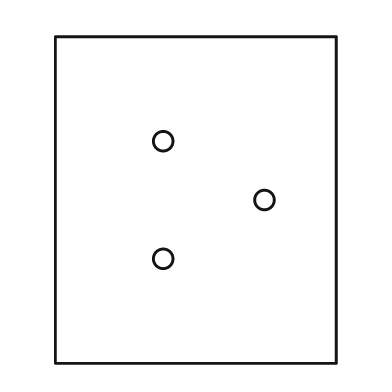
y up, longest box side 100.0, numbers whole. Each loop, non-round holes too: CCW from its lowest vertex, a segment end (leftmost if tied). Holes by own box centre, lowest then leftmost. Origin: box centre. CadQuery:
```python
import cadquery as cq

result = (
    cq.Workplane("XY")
    .moveTo(-43.0, -50.0)
    .lineTo(43.0, -50.0)
    .lineTo(43.0, 50.0)
    .lineTo(-43.0, 50.0)
    .close()
    .moveTo(-10.0, -18.0)
    .circle(3.0)
    .moveTo(21.0, 0.0)
    .circle(3.0)
    .moveTo(-10.0, 18.0)
    .circle(3.0)
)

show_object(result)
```